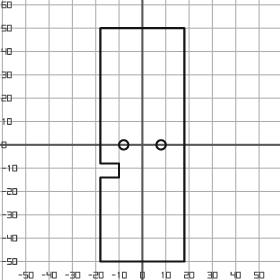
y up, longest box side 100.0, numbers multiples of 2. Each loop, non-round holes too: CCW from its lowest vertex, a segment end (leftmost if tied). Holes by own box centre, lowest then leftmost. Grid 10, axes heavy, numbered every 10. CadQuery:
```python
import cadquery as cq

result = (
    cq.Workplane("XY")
    .moveTo(-18.0, -50.0)
    .lineTo(18.0, -50.0)
    .lineTo(18.0, 50.0)
    .lineTo(-18.0, 50.0)
    .lineTo(-18.0, -8.0)
    .lineTo(-10.0, -8.0)
    .lineTo(-10.0, -14.0)
    .lineTo(-18.0, -14.0)
    .close()
    .moveTo(-8.0, 0.0)
    .circle(2.0)
    .moveTo(8.0, 0.0)
    .circle(2.0)
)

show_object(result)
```